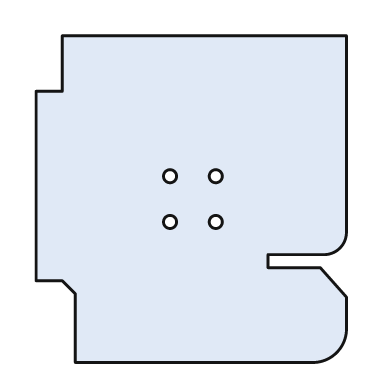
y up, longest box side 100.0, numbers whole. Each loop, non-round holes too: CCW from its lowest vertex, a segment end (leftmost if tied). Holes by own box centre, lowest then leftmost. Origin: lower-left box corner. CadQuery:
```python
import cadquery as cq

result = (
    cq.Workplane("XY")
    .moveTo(12.0, 0.0)
    .lineTo(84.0, 0.0)
    .threePointArc((92.0, 3.0), (95.0, 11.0))
    .lineTo(95.0, 20.0)
    .lineTo(87.0, 29.0)
    .lineTo(71.0, 29.0)
    .lineTo(71.0, 33.0)
    .lineTo(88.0, 33.0)
    .threePointArc((93.0, 35.0), (95.0, 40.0))
    .lineTo(95.0, 100.0)
    .lineTo(8.0, 100.0)
    .lineTo(8.0, 83.0)
    .lineTo(0.0, 83.0)
    .lineTo(0.0, 25.0)
    .lineTo(8.0, 25.0)
    .lineTo(12.0, 21.0)
    .close()
    .moveTo(41.0, 43.0)
    .circle(2.0)
    .moveTo(55.0, 43.0)
    .circle(2.0)
    .moveTo(41.0, 57.0)
    .circle(2.0)
    .moveTo(55.0, 57.0)
    .circle(2.0)
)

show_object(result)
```